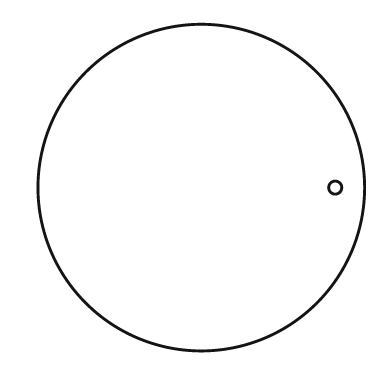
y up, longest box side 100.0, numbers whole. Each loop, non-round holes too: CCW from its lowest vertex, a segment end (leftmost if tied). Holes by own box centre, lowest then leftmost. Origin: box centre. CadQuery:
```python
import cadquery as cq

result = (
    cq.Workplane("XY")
    .moveTo(0.0, 0.0)
    .circle(50.0)
    .moveTo(41.0, 0.0)
    .circle(2.0)
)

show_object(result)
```